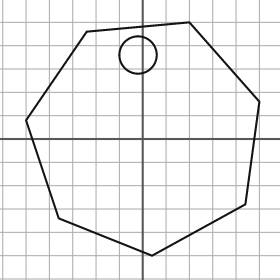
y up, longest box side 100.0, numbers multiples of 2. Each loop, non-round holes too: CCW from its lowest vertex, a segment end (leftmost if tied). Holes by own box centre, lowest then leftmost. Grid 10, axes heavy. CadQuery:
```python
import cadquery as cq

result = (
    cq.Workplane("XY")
    .moveTo(4.0, -50.0)
    .lineTo(44.0, -28.0)
    .lineTo(50.0, 16.0)
    .lineTo(20.0, 50.0)
    .lineTo(-24.0, 46.0)
    .lineTo(-50.0, 8.0)
    .lineTo(-36.0, -34.0)
    .close()
    .moveTo(-2.0, 36.0)
    .circle(8.0)
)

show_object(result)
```